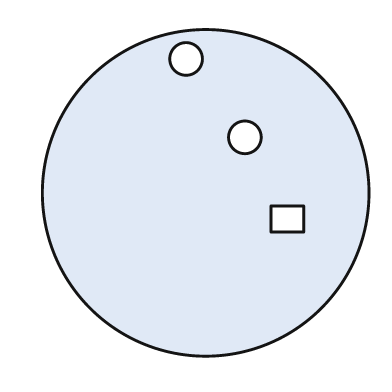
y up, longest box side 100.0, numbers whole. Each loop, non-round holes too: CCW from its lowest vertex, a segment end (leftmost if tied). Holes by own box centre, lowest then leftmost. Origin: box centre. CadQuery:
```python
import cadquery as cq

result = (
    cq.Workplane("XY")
    .moveTo(0.0, 0.0)
    .circle(50.0)
    .moveTo(20.0, -12.0)
    .lineTo(30.0, -12.0)
    .lineTo(30.0, -4.0)
    .lineTo(20.0, -4.0)
    .close()
    .moveTo(12.0, 17.0)
    .circle(5.0)
    .moveTo(-6.0, 41.0)
    .circle(5.0)
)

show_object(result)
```